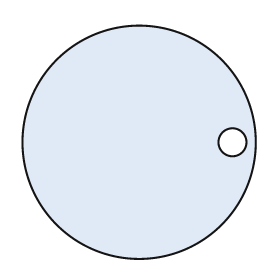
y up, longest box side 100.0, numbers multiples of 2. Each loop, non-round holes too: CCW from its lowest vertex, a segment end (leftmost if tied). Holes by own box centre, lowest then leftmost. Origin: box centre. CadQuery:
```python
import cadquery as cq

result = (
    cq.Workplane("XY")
    .moveTo(0.0, 0.0)
    .circle(50.0)
    .moveTo(40.0, 0.0)
    .circle(6.0)
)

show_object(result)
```